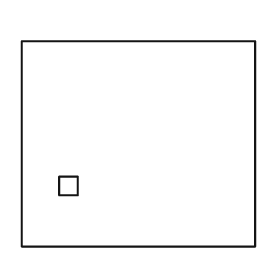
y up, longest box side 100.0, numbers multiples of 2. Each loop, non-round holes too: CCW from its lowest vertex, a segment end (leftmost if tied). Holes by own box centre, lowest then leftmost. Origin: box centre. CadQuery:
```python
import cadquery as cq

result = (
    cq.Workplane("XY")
    .moveTo(-50.0, -44.0)
    .lineTo(50.0, -44.0)
    .lineTo(50.0, 44.0)
    .lineTo(-50.0, 44.0)
    .close()
    .moveTo(-34.0, -22.0)
    .lineTo(-26.0, -22.0)
    .lineTo(-26.0, -14.0)
    .lineTo(-34.0, -14.0)
    .close()
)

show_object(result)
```